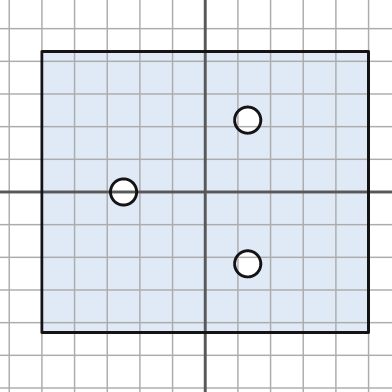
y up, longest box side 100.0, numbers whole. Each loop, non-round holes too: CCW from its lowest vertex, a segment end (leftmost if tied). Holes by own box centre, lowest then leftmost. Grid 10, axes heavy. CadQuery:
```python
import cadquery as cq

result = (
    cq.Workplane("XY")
    .moveTo(-50.0, -43.0)
    .lineTo(50.0, -43.0)
    .lineTo(50.0, 43.0)
    .lineTo(-50.0, 43.0)
    .close()
    .moveTo(13.0, -22.0)
    .circle(4.0)
    .moveTo(-25.0, 0.0)
    .circle(4.0)
    .moveTo(13.0, 22.0)
    .circle(4.0)
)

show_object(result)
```